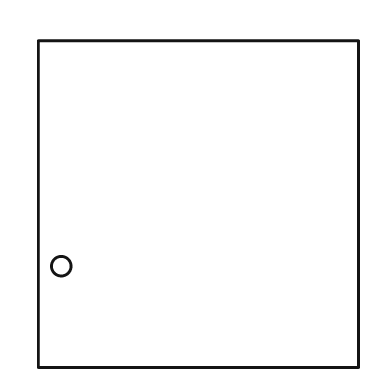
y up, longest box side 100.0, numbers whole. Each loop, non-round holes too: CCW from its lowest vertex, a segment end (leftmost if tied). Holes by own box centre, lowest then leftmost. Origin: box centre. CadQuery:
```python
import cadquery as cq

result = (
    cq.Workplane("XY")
    .moveTo(-49.0, -50.0)
    .lineTo(49.0, -50.0)
    .lineTo(49.0, 50.0)
    .lineTo(-49.0, 50.0)
    .close()
    .moveTo(-42.0, -19.0)
    .circle(3.0)
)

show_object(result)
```